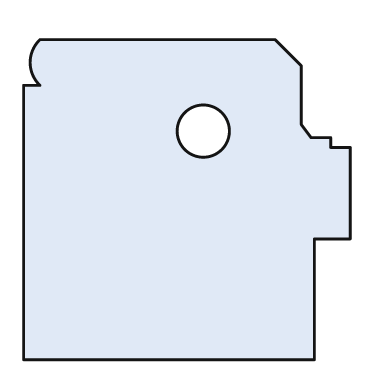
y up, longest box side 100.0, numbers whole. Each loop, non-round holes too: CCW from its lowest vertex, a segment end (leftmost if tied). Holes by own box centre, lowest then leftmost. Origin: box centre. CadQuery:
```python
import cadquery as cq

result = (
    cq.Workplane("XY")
    .moveTo(-50.0, -49.0)
    .lineTo(39.0, -49.0)
    .lineTo(39.0, -12.0)
    .lineTo(50.0, -12.0)
    .lineTo(50.0, 16.0)
    .lineTo(44.0, 16.0)
    .lineTo(44.0, 19.0)
    .lineTo(38.0, 19.0)
    .lineTo(35.0, 23.0)
    .lineTo(35.0, 41.0)
    .lineTo(27.0, 49.0)
    .lineTo(-45.0, 49.0)
    .threePointArc((-48.0, 42.0), (-45.0, 35.0))
    .lineTo(-50.0, 35.0)
    .close()
    .moveTo(5.0, 21.0)
    .circle(8.0)
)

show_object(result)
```